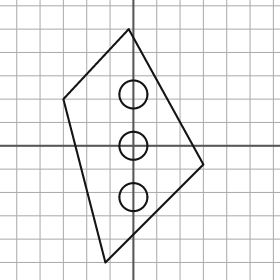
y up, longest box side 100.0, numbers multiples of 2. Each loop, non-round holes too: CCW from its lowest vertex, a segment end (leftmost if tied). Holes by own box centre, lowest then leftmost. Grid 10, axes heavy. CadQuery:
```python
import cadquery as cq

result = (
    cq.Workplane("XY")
    .moveTo(-12.0, -50.0)
    .lineTo(30.0, -8.0)
    .lineTo(-2.0, 50.0)
    .lineTo(-30.0, 20.0)
    .close()
    .moveTo(0.0, -22.0)
    .circle(6.0)
    .moveTo(0.0, 0.0)
    .circle(6.0)
    .moveTo(0.0, 22.0)
    .circle(6.0)
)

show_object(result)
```